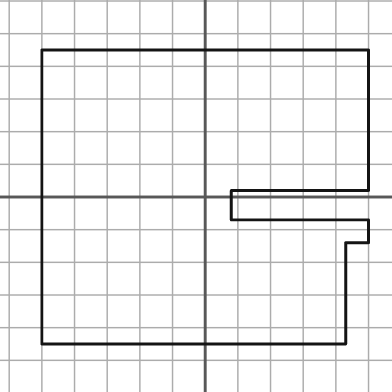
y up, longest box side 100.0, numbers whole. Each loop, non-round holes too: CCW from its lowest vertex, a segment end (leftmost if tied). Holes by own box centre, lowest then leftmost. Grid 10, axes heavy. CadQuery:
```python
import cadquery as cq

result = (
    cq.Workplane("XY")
    .moveTo(-50.0, -45.0)
    .lineTo(43.0, -45.0)
    .lineTo(43.0, -14.0)
    .lineTo(50.0, -14.0)
    .lineTo(50.0, -7.0)
    .lineTo(8.0, -7.0)
    .lineTo(8.0, 2.0)
    .lineTo(50.0, 2.0)
    .lineTo(50.0, 45.0)
    .lineTo(-50.0, 45.0)
    .close()
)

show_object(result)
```